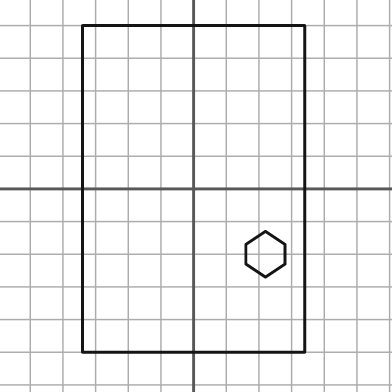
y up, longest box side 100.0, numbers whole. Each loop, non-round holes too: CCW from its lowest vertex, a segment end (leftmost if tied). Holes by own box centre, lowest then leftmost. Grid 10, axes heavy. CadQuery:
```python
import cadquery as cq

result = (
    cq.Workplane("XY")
    .moveTo(-34.0, -50.0)
    .lineTo(34.0, -50.0)
    .lineTo(34.0, 50.0)
    .lineTo(-34.0, 50.0)
    .close()
    .moveTo(22.0, -27.0)
    .lineTo(28.0, -23.0)
    .lineTo(28.0, -17.0)
    .lineTo(22.0, -13.0)
    .lineTo(16.0, -17.0)
    .lineTo(16.0, -23.0)
    .close()
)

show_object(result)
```